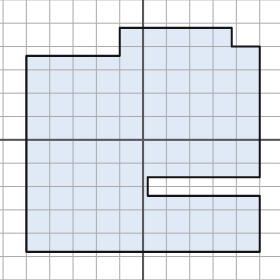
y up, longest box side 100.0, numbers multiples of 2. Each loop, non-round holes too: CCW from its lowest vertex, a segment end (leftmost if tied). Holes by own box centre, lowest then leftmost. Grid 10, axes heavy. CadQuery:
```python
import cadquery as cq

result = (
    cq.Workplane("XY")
    .moveTo(-50.0, -48.0)
    .lineTo(50.0, -48.0)
    .lineTo(50.0, -24.0)
    .lineTo(2.0, -24.0)
    .lineTo(2.0, -16.0)
    .lineTo(50.0, -16.0)
    .lineTo(50.0, 40.0)
    .lineTo(38.0, 40.0)
    .lineTo(38.0, 48.0)
    .lineTo(-10.0, 48.0)
    .lineTo(-10.0, 36.0)
    .lineTo(-50.0, 36.0)
    .close()
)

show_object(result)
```